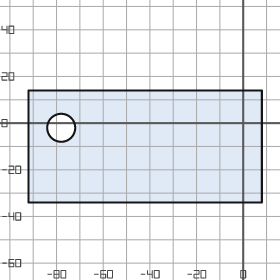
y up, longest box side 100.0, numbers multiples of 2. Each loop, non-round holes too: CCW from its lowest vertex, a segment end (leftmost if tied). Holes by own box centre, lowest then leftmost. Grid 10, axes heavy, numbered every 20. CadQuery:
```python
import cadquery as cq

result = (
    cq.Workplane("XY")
    .moveTo(-92.0, -34.0)
    .lineTo(8.0, -34.0)
    .lineTo(8.0, 14.0)
    .lineTo(-92.0, 14.0)
    .close()
    .moveTo(-78.0, -2.0)
    .circle(6.0)
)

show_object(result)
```